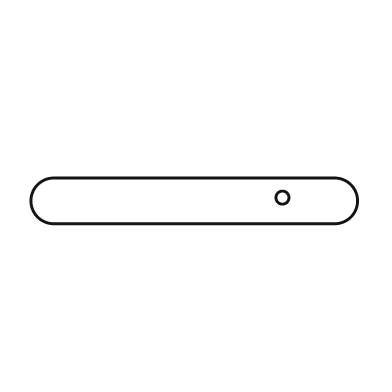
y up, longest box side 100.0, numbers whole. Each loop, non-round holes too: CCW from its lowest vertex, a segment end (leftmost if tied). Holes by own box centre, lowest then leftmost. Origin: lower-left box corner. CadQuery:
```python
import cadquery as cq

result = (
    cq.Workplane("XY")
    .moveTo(7.0, 0.0)
    .lineTo(93.0, 0.0)
    .threePointArc((100.0, 7.0), (93.0, 14.0))
    .lineTo(7.0, 14.0)
    .threePointArc((0.0, 7.0), (7.0, 0.0))
    .close()
    .moveTo(77.0, 8.0)
    .circle(2.0)
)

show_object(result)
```